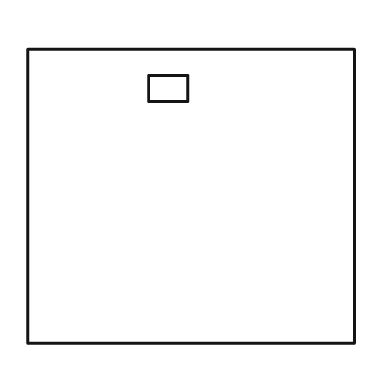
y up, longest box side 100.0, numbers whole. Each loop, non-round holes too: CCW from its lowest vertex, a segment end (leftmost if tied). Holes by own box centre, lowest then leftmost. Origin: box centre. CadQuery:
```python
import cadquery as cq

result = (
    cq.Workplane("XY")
    .moveTo(-50.0, -45.0)
    .lineTo(50.0, -45.0)
    .lineTo(50.0, 45.0)
    .lineTo(-50.0, 45.0)
    .close()
    .moveTo(-13.0, 29.0)
    .lineTo(-1.0, 29.0)
    .lineTo(-1.0, 37.0)
    .lineTo(-13.0, 37.0)
    .close()
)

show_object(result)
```